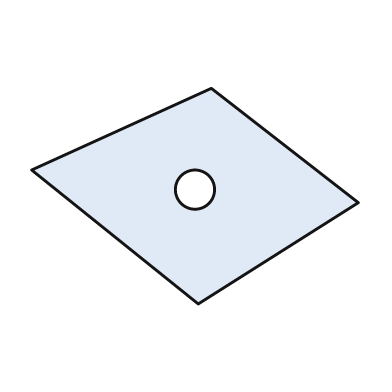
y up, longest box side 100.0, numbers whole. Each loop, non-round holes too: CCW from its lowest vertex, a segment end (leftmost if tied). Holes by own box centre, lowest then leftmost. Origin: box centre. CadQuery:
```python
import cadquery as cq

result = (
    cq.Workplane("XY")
    .moveTo(1.0, -33.0)
    .lineTo(50.0, -2.0)
    .lineTo(5.0, 33.0)
    .lineTo(-50.0, 8.0)
    .close()
    .moveTo(0.0, 2.0)
    .circle(6.0)
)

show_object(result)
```